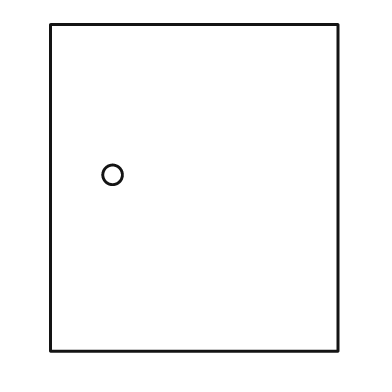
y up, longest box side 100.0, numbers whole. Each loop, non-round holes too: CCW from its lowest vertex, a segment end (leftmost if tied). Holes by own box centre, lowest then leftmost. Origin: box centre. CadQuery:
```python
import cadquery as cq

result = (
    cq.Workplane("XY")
    .moveTo(-44.0, -50.0)
    .lineTo(44.0, -50.0)
    .lineTo(44.0, 50.0)
    .lineTo(-44.0, 50.0)
    .close()
    .moveTo(-25.0, 4.0)
    .circle(3.0)
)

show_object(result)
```